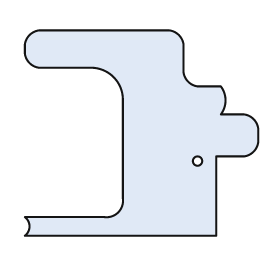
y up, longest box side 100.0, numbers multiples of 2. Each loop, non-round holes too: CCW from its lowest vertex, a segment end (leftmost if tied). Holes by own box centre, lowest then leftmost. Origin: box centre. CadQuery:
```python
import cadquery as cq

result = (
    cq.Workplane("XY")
    .moveTo(-50.0, -44.0)
    .lineTo(32.0, -44.0)
    .lineTo(32.0, -10.0)
    .lineTo(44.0, -10.0)
    .threePointArc((48.0, -8.0), (50.0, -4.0))
    .lineTo(50.0, 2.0)
    .threePointArc((48.0, 6.0), (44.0, 8.0))
    .lineTo(34.0, 8.0)
    .threePointArc((36.0, 14.0), (34.0, 20.0))
    .lineTo(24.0, 20.0)
    .threePointArc((20.0, 22.0), (18.0, 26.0))
    .lineTo(18.0, 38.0)
    .threePointArc((16.0, 42.0), (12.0, 44.0))
    .lineTo(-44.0, 44.0)
    .threePointArc((-48.0, 42.0), (-50.0, 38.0))
    .lineTo(-50.0, 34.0)
    .threePointArc((-48.0, 30.0), (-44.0, 28.0))
    .lineTo(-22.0, 28.0)
    .threePointArc((-12.0, 24.0), (-8.0, 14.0))
    .lineTo(-8.0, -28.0)
    .threePointArc((-10.0, -34.0), (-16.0, -36.0))
    .lineTo(-50.0, -36.0)
    .threePointArc((-48.0, -40.0), (-50.0, -44.0))
    .close()
    .moveTo(24.0, -12.0)
    .circle(2.0)
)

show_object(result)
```